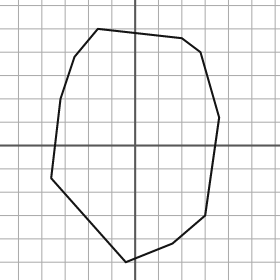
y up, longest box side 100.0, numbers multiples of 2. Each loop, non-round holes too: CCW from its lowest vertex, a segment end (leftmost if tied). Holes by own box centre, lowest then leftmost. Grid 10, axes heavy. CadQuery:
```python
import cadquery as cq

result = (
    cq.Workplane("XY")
    .moveTo(-4.0, -50.0)
    .lineTo(16.0, -42.0)
    .lineTo(30.0, -30.0)
    .lineTo(36.0, 12.0)
    .lineTo(28.0, 40.0)
    .lineTo(20.0, 46.0)
    .lineTo(-16.0, 50.0)
    .lineTo(-26.0, 38.0)
    .lineTo(-32.0, 20.0)
    .lineTo(-36.0, -14.0)
    .close()
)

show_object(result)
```